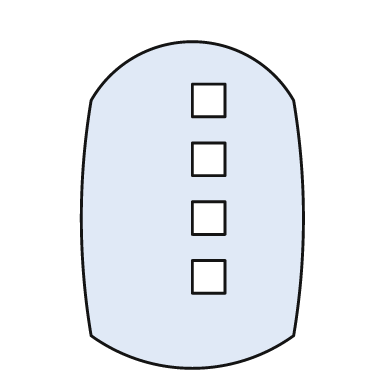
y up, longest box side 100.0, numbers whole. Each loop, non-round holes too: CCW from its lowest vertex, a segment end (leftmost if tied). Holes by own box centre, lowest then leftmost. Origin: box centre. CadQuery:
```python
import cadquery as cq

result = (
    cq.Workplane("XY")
    .moveTo(-31.0, -40.0)
    .threePointArc((0.0, -50.0), (31.0, -40.0))
    .threePointArc((34.0, -4.0), (31.0, 32.0))
    .threePointArc((0.0, 50.0), (-31.0, 32.0))
    .threePointArc((-34.0, -4.0), (-31.0, -40.0))
    .close()
    .moveTo(0.0, -27.0)
    .lineTo(10.0, -27.0)
    .lineTo(10.0, -17.0)
    .lineTo(0.0, -17.0)
    .close()
    .moveTo(0.0, -9.0)
    .lineTo(10.0, -9.0)
    .lineTo(10.0, 1.0)
    .lineTo(0.0, 1.0)
    .close()
    .moveTo(0.0, 9.0)
    .lineTo(10.0, 9.0)
    .lineTo(10.0, 19.0)
    .lineTo(0.0, 19.0)
    .close()
    .moveTo(0.0, 27.0)
    .lineTo(10.0, 27.0)
    .lineTo(10.0, 37.0)
    .lineTo(0.0, 37.0)
    .close()
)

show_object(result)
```